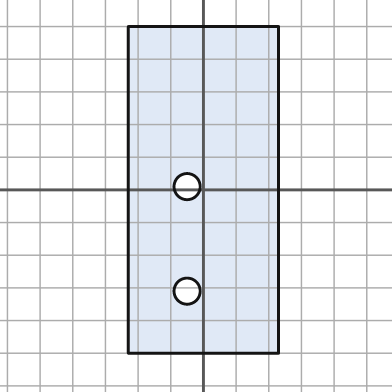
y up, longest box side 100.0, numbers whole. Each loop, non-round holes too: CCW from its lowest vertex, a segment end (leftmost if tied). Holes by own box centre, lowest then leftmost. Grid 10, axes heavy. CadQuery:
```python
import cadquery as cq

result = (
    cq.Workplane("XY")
    .moveTo(-23.0, -50.0)
    .lineTo(23.0, -50.0)
    .lineTo(23.0, 50.0)
    .lineTo(-23.0, 50.0)
    .close()
    .moveTo(-5.0, -31.0)
    .circle(4.0)
    .moveTo(-5.0, 1.0)
    .circle(4.0)
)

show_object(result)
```